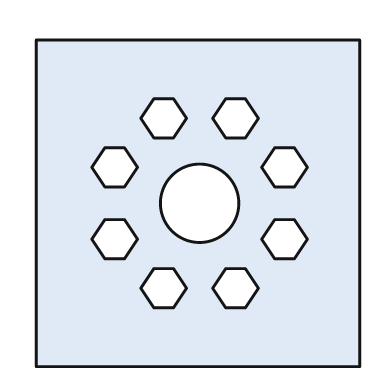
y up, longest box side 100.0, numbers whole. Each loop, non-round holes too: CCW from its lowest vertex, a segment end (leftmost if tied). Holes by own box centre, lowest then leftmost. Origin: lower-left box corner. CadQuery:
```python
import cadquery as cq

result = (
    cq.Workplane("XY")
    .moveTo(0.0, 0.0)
    .lineTo(99.0, 0.0)
    .lineTo(99.0, 100.0)
    .lineTo(0.0, 100.0)
    .close()
    .moveTo(36.0, 18.0)
    .lineTo(42.0, 18.0)
    .lineTo(46.0, 24.0)
    .lineTo(42.0, 30.0)
    .lineTo(36.0, 30.0)
    .lineTo(32.0, 24.0)
    .close()
    .moveTo(58.0, 18.0)
    .lineTo(64.0, 18.0)
    .lineTo(68.0, 24.0)
    .lineTo(64.0, 30.0)
    .lineTo(58.0, 30.0)
    .lineTo(54.0, 24.0)
    .close()
    .moveTo(21.0, 33.0)
    .lineTo(27.0, 33.0)
    .lineTo(31.0, 39.0)
    .lineTo(27.0, 45.0)
    .lineTo(21.0, 45.0)
    .lineTo(17.0, 39.0)
    .close()
    .moveTo(73.0, 33.0)
    .lineTo(79.0, 33.0)
    .lineTo(83.0, 39.0)
    .lineTo(79.0, 45.0)
    .lineTo(73.0, 45.0)
    .lineTo(69.0, 39.0)
    .close()
    .moveTo(50.0, 50.0)
    .circle(12.0)
    .moveTo(21.0, 55.0)
    .lineTo(27.0, 55.0)
    .lineTo(31.0, 61.0)
    .lineTo(27.0, 67.0)
    .lineTo(21.0, 67.0)
    .lineTo(17.0, 61.0)
    .close()
    .moveTo(73.0, 55.0)
    .lineTo(79.0, 55.0)
    .lineTo(83.0, 61.0)
    .lineTo(79.0, 67.0)
    .lineTo(73.0, 67.0)
    .lineTo(69.0, 61.0)
    .close()
    .moveTo(36.0, 70.0)
    .lineTo(42.0, 70.0)
    .lineTo(46.0, 76.0)
    .lineTo(42.0, 82.0)
    .lineTo(36.0, 82.0)
    .lineTo(32.0, 76.0)
    .close()
    .moveTo(58.0, 70.0)
    .lineTo(64.0, 70.0)
    .lineTo(68.0, 76.0)
    .lineTo(64.0, 82.0)
    .lineTo(58.0, 82.0)
    .lineTo(54.0, 76.0)
    .close()
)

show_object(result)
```